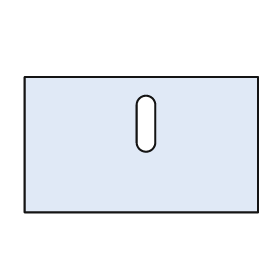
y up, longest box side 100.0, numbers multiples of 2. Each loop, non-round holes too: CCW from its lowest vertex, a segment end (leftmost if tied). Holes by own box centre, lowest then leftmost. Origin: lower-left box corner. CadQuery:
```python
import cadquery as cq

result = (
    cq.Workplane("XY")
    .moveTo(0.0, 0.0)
    .lineTo(100.0, 0.0)
    .lineTo(100.0, 58.0)
    .lineTo(0.0, 58.0)
    .close()
    .moveTo(48.0, 30.0)
    .threePointArc((52.0, 26.0), (56.0, 30.0))
    .lineTo(56.0, 46.0)
    .threePointArc((52.0, 50.0), (48.0, 46.0))
    .close()
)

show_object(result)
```